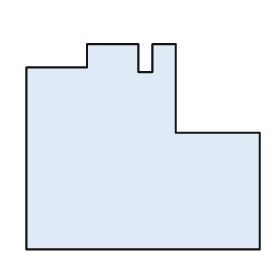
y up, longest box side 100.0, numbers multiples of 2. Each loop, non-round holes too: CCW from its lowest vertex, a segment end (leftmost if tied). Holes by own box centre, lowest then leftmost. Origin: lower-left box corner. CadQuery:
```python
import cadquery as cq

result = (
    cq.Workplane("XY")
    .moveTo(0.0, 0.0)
    .lineTo(100.0, 0.0)
    .lineTo(100.0, 50.0)
    .lineTo(64.0, 50.0)
    .lineTo(64.0, 88.0)
    .lineTo(54.0, 88.0)
    .lineTo(54.0, 76.0)
    .lineTo(48.0, 76.0)
    .lineTo(48.0, 88.0)
    .lineTo(26.0, 88.0)
    .lineTo(26.0, 78.0)
    .lineTo(0.0, 78.0)
    .close()
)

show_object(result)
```